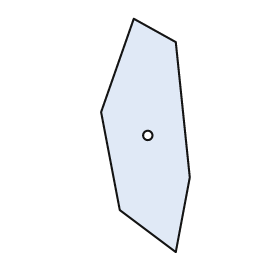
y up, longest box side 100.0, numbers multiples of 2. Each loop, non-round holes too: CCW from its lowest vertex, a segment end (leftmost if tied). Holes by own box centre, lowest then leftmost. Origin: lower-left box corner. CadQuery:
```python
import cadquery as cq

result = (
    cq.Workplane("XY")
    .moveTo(32.0, 0.0)
    .lineTo(38.0, 32.0)
    .lineTo(32.0, 90.0)
    .lineTo(14.0, 100.0)
    .lineTo(0.0, 60.0)
    .lineTo(8.0, 18.0)
    .close()
    .moveTo(20.0, 50.0)
    .circle(2.0)
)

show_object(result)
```